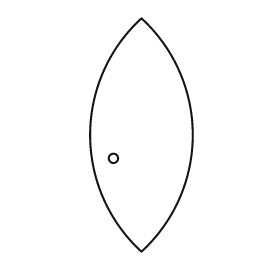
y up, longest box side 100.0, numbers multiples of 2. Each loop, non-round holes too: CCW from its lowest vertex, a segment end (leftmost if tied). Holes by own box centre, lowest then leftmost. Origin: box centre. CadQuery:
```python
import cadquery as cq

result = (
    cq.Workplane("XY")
    .moveTo(0.0, -50.0)
    .threePointArc((22.0, 0.0), (0.0, 50.0))
    .threePointArc((-22.0, 0.0), (0.0, -50.0))
    .close()
    .moveTo(-12.0, -10.0)
    .circle(2.0)
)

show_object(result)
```